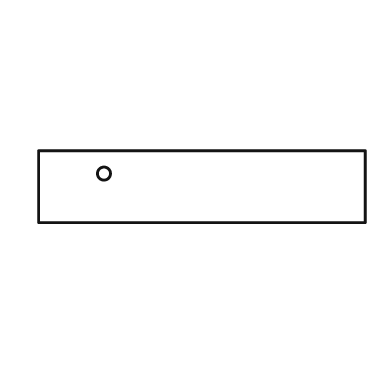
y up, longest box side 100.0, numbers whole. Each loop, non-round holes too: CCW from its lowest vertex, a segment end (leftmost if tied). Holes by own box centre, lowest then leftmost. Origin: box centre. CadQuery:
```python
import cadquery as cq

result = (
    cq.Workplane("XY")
    .moveTo(-50.0, -11.0)
    .lineTo(50.0, -11.0)
    .lineTo(50.0, 11.0)
    .lineTo(-50.0, 11.0)
    .close()
    .moveTo(-30.0, 4.0)
    .circle(2.0)
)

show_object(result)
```